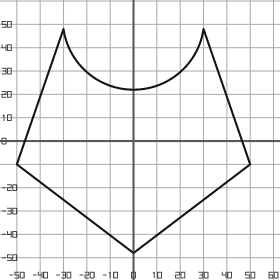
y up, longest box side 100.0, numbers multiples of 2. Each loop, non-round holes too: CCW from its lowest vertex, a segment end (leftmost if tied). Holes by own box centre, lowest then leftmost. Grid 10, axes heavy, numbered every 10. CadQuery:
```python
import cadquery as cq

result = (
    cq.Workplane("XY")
    .moveTo(0.0, -48.0)
    .lineTo(50.0, -10.0)
    .lineTo(30.0, 48.0)
    .threePointArc((0.0, 22.0), (-30.0, 48.0))
    .lineTo(-50.0, -10.0)
    .close()
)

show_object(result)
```